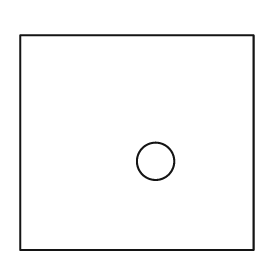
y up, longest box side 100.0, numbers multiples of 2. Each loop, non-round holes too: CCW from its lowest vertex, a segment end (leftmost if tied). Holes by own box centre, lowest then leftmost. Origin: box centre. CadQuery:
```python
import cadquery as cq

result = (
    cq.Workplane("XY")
    .moveTo(-50.0, -46.0)
    .lineTo(50.0, -46.0)
    .lineTo(50.0, 46.0)
    .lineTo(-50.0, 46.0)
    .close()
    .moveTo(8.0, -8.0)
    .circle(8.0)
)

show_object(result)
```